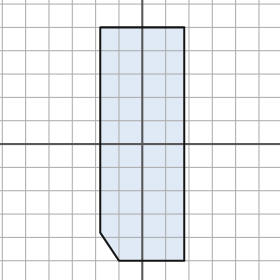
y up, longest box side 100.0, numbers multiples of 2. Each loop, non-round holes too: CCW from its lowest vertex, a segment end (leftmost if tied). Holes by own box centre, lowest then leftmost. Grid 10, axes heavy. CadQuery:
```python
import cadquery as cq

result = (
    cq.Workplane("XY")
    .moveTo(-10.0, -50.0)
    .lineTo(18.0, -50.0)
    .lineTo(18.0, 50.0)
    .lineTo(-18.0, 50.0)
    .lineTo(-18.0, -38.0)
    .close()
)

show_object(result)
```